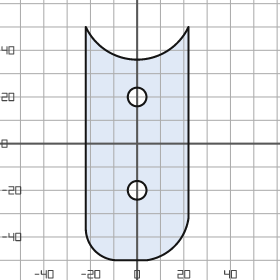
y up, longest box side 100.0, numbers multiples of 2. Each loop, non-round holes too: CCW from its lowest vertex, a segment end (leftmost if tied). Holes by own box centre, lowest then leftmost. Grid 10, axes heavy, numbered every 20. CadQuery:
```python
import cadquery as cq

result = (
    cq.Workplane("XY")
    .moveTo(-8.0, -50.0)
    .lineTo(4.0, -50.0)
    .threePointArc((16.0, -44.0), (22.0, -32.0))
    .lineTo(22.0, 50.0)
    .threePointArc((0.0, 36.0), (-22.0, 50.0))
    .lineTo(-22.0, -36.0)
    .threePointArc((-18.0, -46.0), (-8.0, -50.0))
    .close()
    .moveTo(0.0, -20.0)
    .circle(4.0)
    .moveTo(0.0, 20.0)
    .circle(4.0)
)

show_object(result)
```